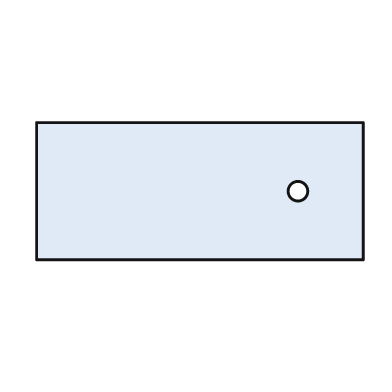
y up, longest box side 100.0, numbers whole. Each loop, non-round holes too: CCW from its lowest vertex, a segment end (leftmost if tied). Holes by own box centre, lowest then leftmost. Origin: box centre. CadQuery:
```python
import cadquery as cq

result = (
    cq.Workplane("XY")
    .moveTo(-50.0, -21.0)
    .lineTo(50.0, -21.0)
    .lineTo(50.0, 21.0)
    .lineTo(-50.0, 21.0)
    .close()
    .moveTo(30.0, 0.0)
    .circle(3.0)
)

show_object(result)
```